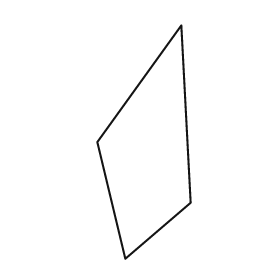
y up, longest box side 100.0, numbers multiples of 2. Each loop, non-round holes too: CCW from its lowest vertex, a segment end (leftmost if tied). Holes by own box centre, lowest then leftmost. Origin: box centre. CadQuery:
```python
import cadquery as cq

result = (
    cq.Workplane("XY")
    .moveTo(-8.0, -50.0)
    .lineTo(20.0, -26.0)
    .lineTo(16.0, 50.0)
    .lineTo(-20.0, 0.0)
    .close()
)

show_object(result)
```